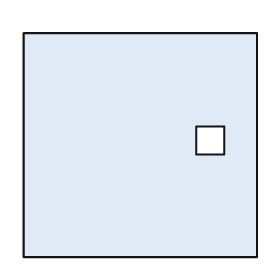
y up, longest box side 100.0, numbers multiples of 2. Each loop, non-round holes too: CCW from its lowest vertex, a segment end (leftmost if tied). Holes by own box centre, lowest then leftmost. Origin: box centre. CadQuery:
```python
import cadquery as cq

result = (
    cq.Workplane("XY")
    .moveTo(-50.0, -48.0)
    .lineTo(50.0, -48.0)
    .lineTo(50.0, 48.0)
    .lineTo(-50.0, 48.0)
    .close()
    .moveTo(24.0, -4.0)
    .lineTo(36.0, -4.0)
    .lineTo(36.0, 8.0)
    .lineTo(24.0, 8.0)
    .close()
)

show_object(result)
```